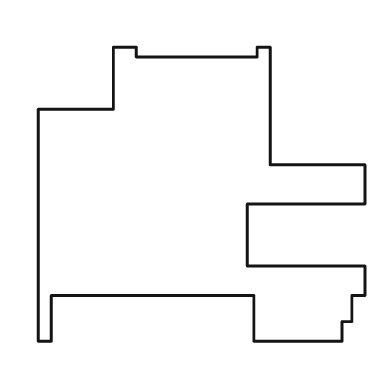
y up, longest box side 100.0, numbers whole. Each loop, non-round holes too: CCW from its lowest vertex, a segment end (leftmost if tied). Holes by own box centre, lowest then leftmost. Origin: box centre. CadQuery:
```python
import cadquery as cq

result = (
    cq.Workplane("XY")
    .moveTo(-50.0, -45.0)
    .lineTo(-46.0, -45.0)
    .lineTo(-46.0, -31.0)
    .lineTo(16.0, -31.0)
    .lineTo(16.0, -45.0)
    .lineTo(43.0, -45.0)
    .lineTo(43.0, -39.0)
    .lineTo(46.0, -39.0)
    .lineTo(46.0, -31.0)
    .lineTo(50.0, -31.0)
    .lineTo(50.0, -22.0)
    .lineTo(14.0, -22.0)
    .lineTo(14.0, -3.0)
    .lineTo(50.0, -3.0)
    .lineTo(50.0, 9.0)
    .lineTo(21.0, 9.0)
    .lineTo(21.0, 45.0)
    .lineTo(17.0, 45.0)
    .lineTo(17.0, 42.0)
    .lineTo(-20.0, 42.0)
    .lineTo(-20.0, 45.0)
    .lineTo(-27.0, 45.0)
    .lineTo(-27.0, 26.0)
    .lineTo(-50.0, 26.0)
    .close()
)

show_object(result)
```